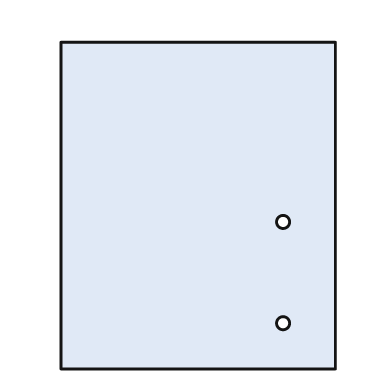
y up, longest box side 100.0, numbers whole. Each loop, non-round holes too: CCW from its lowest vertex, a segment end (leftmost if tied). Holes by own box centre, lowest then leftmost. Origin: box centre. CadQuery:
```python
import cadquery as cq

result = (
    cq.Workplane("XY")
    .moveTo(-42.0, -50.0)
    .lineTo(42.0, -50.0)
    .lineTo(42.0, 50.0)
    .lineTo(-42.0, 50.0)
    .close()
    .moveTo(26.0, -36.0)
    .circle(2.0)
    .moveTo(26.0, -5.0)
    .circle(2.0)
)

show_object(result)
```